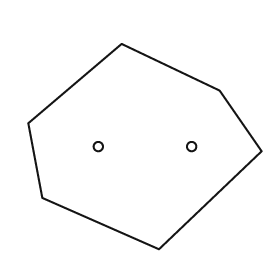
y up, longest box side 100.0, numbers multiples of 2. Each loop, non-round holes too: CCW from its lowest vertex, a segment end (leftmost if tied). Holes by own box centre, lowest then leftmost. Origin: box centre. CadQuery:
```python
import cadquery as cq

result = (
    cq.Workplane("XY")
    .moveTo(6.0, -44.0)
    .lineTo(50.0, -2.0)
    .lineTo(32.0, 24.0)
    .lineTo(-10.0, 44.0)
    .lineTo(-50.0, 10.0)
    .lineTo(-44.0, -22.0)
    .close()
    .moveTo(-20.0, 0.0)
    .circle(2.0)
    .moveTo(20.0, 0.0)
    .circle(2.0)
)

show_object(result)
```